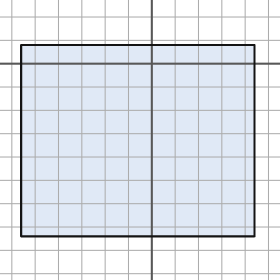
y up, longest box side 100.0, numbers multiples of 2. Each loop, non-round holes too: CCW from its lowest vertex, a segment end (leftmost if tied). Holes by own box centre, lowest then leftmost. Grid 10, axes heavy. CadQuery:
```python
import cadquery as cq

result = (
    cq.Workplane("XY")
    .moveTo(-56.0, -74.0)
    .lineTo(44.0, -74.0)
    .lineTo(44.0, 8.0)
    .lineTo(-56.0, 8.0)
    .close()
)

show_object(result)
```